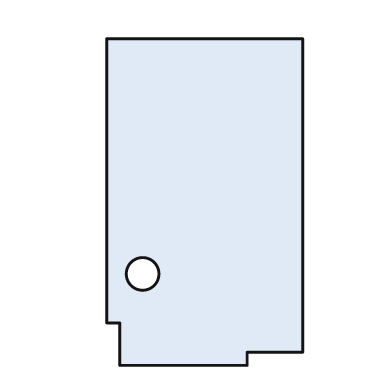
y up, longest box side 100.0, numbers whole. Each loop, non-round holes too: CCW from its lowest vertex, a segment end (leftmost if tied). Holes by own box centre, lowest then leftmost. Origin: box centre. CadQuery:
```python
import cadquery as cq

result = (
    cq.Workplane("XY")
    .moveTo(-26.0, -50.0)
    .lineTo(13.0, -50.0)
    .lineTo(13.0, -46.0)
    .lineTo(30.0, -46.0)
    .lineTo(30.0, 50.0)
    .lineTo(-30.0, 50.0)
    .lineTo(-30.0, -37.0)
    .lineTo(-26.0, -37.0)
    .close()
    .moveTo(-19.0, -22.0)
    .circle(5.0)
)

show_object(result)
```